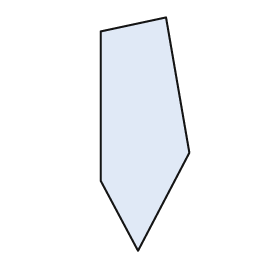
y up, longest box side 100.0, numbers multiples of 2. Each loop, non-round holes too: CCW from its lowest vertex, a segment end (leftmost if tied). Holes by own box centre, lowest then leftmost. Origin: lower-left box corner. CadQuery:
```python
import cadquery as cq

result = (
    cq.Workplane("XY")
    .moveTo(16.0, 0.0)
    .lineTo(38.0, 42.0)
    .lineTo(28.0, 100.0)
    .lineTo(0.0, 94.0)
    .lineTo(0.0, 30.0)
    .close()
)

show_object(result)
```